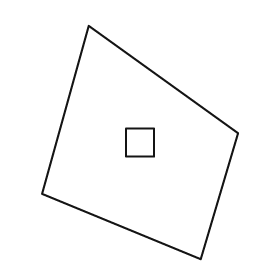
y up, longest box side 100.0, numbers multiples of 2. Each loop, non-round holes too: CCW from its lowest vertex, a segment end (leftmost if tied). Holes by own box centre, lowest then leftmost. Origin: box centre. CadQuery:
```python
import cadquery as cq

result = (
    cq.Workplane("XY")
    .moveTo(26.0, -50.0)
    .lineTo(42.0, 4.0)
    .lineTo(-22.0, 50.0)
    .lineTo(-42.0, -22.0)
    .close()
    .moveTo(-6.0, -6.0)
    .lineTo(6.0, -6.0)
    .lineTo(6.0, 6.0)
    .lineTo(-6.0, 6.0)
    .close()
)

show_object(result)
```